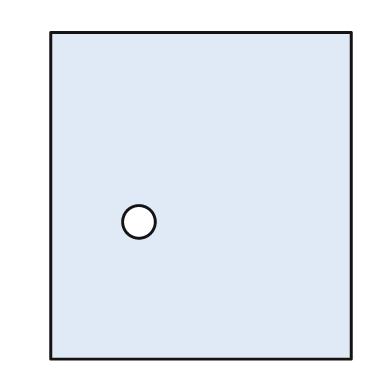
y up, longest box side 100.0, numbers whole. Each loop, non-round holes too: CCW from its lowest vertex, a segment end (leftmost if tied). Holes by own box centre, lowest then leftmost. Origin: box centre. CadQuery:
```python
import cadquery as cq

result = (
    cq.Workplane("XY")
    .moveTo(-46.0, -50.0)
    .lineTo(46.0, -50.0)
    .lineTo(46.0, 50.0)
    .lineTo(-46.0, 50.0)
    .close()
    .moveTo(-19.0, -8.0)
    .circle(5.0)
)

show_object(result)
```